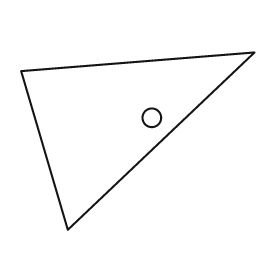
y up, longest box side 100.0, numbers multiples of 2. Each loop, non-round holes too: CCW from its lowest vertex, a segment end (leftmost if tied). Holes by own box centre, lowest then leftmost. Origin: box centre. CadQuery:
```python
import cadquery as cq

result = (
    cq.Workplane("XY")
    .moveTo(-30.0, -38.0)
    .lineTo(50.0, 38.0)
    .lineTo(-50.0, 30.0)
    .close()
    .moveTo(6.0, 10.0)
    .circle(4.0)
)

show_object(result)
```